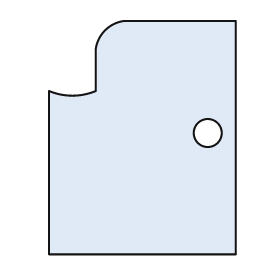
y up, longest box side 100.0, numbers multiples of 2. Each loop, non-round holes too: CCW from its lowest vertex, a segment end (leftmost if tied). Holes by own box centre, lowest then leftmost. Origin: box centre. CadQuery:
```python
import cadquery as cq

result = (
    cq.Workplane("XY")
    .moveTo(-40.0, -50.0)
    .lineTo(40.0, -50.0)
    .lineTo(40.0, 50.0)
    .lineTo(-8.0, 50.0)
    .threePointArc((-16.0, 46.0), (-20.0, 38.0))
    .lineTo(-20.0, 20.0)
    .threePointArc((-30.0, 18.0), (-40.0, 20.0))
    .close()
    .moveTo(28.0, 2.0)
    .circle(6.0)
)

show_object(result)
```